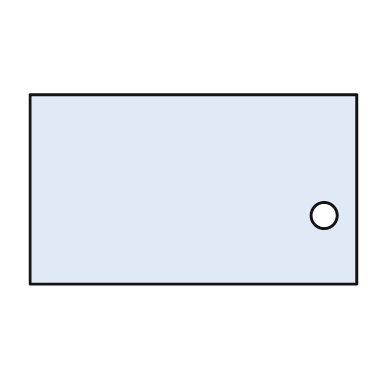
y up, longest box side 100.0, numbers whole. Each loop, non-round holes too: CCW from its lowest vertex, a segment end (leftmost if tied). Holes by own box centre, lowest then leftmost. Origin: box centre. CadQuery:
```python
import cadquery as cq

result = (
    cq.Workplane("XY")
    .moveTo(-50.0, -29.0)
    .lineTo(50.0, -29.0)
    .lineTo(50.0, 29.0)
    .lineTo(-50.0, 29.0)
    .close()
    .moveTo(40.0, -8.0)
    .circle(4.0)
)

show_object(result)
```